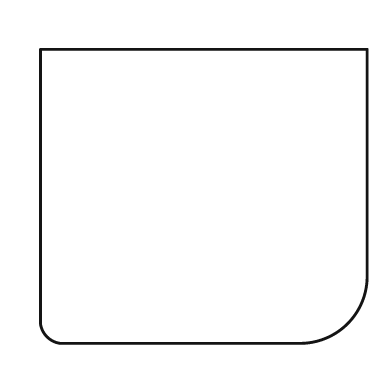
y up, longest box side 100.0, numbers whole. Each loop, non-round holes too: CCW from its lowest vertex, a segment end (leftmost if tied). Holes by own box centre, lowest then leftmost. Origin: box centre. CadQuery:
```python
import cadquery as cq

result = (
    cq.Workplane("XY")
    .moveTo(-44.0, -45.0)
    .lineTo(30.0, -45.0)
    .threePointArc((44.0, -39.0), (50.0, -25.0))
    .lineTo(50.0, 45.0)
    .lineTo(-50.0, 45.0)
    .lineTo(-50.0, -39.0)
    .threePointArc((-48.0, -43.0), (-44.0, -45.0))
    .close()
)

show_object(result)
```